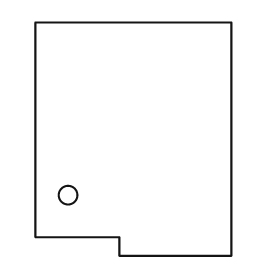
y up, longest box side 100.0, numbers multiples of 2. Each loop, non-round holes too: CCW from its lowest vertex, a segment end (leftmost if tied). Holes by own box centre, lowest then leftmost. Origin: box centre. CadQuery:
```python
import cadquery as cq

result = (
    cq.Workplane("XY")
    .moveTo(-6.0, -50.0)
    .lineTo(42.0, -50.0)
    .lineTo(42.0, 50.0)
    .lineTo(-42.0, 50.0)
    .lineTo(-42.0, -42.0)
    .lineTo(-6.0, -42.0)
    .close()
    .moveTo(-28.0, -24.0)
    .circle(4.0)
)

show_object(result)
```